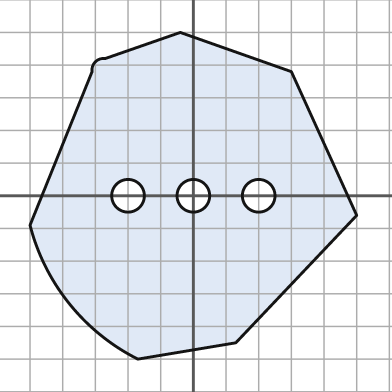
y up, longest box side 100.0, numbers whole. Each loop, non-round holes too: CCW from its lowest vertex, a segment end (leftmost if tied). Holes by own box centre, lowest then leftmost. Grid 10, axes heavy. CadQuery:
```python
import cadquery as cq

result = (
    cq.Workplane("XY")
    .moveTo(-17.0, -50.0)
    .lineTo(13.0, -45.0)
    .lineTo(50.0, -6.0)
    .lineTo(30.0, 38.0)
    .lineTo(-4.0, 50.0)
    .lineTo(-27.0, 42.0)
    .threePointArc((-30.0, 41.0), (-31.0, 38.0))
    .lineTo(-50.0, -9.0)
    .threePointArc((-38.0, -33.0), (-17.0, -50.0))
    .close()
    .moveTo(-20.0, 0.0)
    .circle(5.0)
    .moveTo(0.0, 0.0)
    .circle(5.0)
    .moveTo(20.0, 0.0)
    .circle(5.0)
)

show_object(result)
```